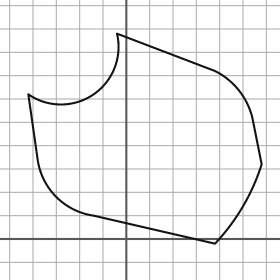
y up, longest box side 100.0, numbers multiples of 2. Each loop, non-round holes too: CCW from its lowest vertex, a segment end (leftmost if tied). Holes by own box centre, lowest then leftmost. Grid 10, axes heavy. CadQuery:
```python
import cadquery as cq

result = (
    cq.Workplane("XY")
    .moveTo(38.0, -2.0)
    .threePointArc((50.0, 14.0), (58.0, 32.0))
    .lineTo(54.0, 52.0)
    .threePointArc((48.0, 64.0), (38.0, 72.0))
    .lineTo(-4.0, 88.0)
    .threePointArc((-14.0, 62.0), (-42.0, 62.0))
    .lineTo(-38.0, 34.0)
    .threePointArc((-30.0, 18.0), (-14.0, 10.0))
    .close()
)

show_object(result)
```